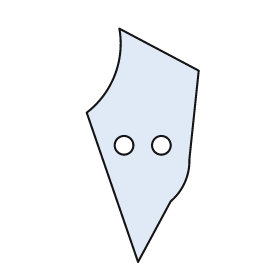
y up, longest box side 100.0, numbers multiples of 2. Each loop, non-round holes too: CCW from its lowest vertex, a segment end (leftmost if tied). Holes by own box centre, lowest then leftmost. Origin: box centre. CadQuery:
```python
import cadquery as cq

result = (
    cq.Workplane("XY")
    .moveTo(-2.0, -50.0)
    .lineTo(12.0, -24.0)
    .threePointArc((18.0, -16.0), (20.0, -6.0))
    .lineTo(24.0, 32.0)
    .lineTo(-10.0, 50.0)
    .threePointArc((-12.0, 30.0), (-24.0, 14.0))
    .close()
    .moveTo(-8.0, 0.0)
    .circle(4.0)
    .moveTo(8.0, 0.0)
    .circle(4.0)
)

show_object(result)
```